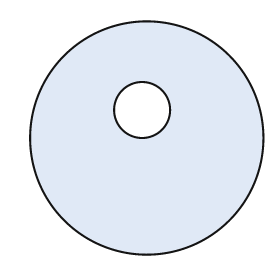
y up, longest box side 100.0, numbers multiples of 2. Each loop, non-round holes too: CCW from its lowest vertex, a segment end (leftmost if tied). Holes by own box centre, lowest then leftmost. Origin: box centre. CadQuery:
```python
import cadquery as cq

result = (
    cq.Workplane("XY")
    .moveTo(0.0, 0.0)
    .circle(50.0)
    .moveTo(-2.0, 12.0)
    .circle(12.0)
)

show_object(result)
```